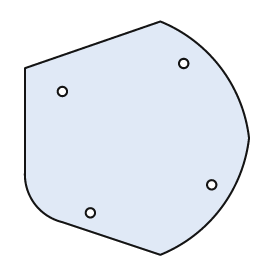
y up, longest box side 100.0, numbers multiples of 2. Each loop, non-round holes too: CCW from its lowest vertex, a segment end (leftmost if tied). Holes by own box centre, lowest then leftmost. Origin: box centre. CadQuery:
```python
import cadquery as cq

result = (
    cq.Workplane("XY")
    .moveTo(10.0, -50.0)
    .threePointArc((36.0, -30.0), (48.0, 0.0))
    .threePointArc((36.0, 30.0), (10.0, 50.0))
    .lineTo(-48.0, 30.0)
    .lineTo(-48.0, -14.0)
    .threePointArc((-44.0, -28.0), (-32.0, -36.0))
    .close()
    .moveTo(-20.0, -32.0)
    .circle(2.0)
    .moveTo(32.0, -20.0)
    .circle(2.0)
    .moveTo(-32.0, 20.0)
    .circle(2.0)
    .moveTo(20.0, 32.0)
    .circle(2.0)
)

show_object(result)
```